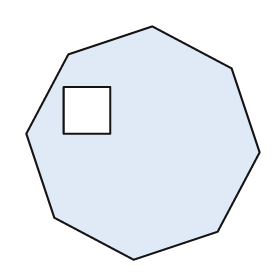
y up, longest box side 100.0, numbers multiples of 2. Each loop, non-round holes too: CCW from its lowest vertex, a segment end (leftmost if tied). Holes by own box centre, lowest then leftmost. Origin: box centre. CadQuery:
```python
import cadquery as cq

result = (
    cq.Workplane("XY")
    .moveTo(-4.0, -50.0)
    .lineTo(32.0, -38.0)
    .lineTo(50.0, -4.0)
    .lineTo(38.0, 32.0)
    .lineTo(4.0, 50.0)
    .lineTo(-32.0, 38.0)
    .lineTo(-50.0, 4.0)
    .lineTo(-38.0, -32.0)
    .close()
    .moveTo(-34.0, 4.0)
    .lineTo(-14.0, 4.0)
    .lineTo(-14.0, 24.0)
    .lineTo(-34.0, 24.0)
    .close()
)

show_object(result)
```